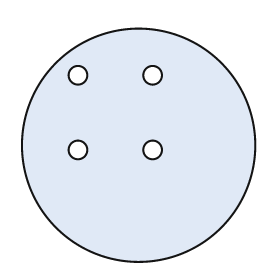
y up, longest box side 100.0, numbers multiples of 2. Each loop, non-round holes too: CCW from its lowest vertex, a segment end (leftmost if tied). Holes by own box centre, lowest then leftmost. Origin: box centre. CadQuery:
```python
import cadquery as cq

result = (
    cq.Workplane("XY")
    .moveTo(0.0, 0.0)
    .circle(50.0)
    .moveTo(-26.0, -2.0)
    .circle(4.0)
    .moveTo(6.0, -2.0)
    .circle(4.0)
    .moveTo(-26.0, 30.0)
    .circle(4.0)
    .moveTo(6.0, 30.0)
    .circle(4.0)
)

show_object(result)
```